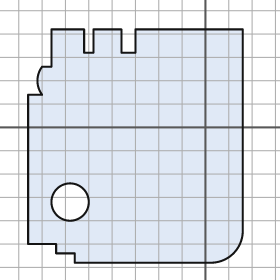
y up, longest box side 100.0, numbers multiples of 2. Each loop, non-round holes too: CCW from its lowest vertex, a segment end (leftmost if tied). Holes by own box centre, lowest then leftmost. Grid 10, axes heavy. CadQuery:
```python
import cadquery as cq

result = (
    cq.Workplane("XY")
    .moveTo(-56.0, -58.0)
    .lineTo(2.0, -58.0)
    .threePointArc((12.0, -54.0), (16.0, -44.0))
    .lineTo(16.0, 42.0)
    .lineTo(-30.0, 42.0)
    .lineTo(-30.0, 32.0)
    .lineTo(-36.0, 32.0)
    .lineTo(-36.0, 42.0)
    .lineTo(-48.0, 42.0)
    .lineTo(-48.0, 32.0)
    .lineTo(-52.0, 32.0)
    .lineTo(-52.0, 42.0)
    .lineTo(-66.0, 42.0)
    .lineTo(-66.0, 26.0)
    .lineTo(-70.0, 26.0)
    .threePointArc((-72.0, 20.0), (-70.0, 14.0))
    .lineTo(-76.0, 14.0)
    .lineTo(-76.0, -50.0)
    .lineTo(-64.0, -50.0)
    .lineTo(-64.0, -54.0)
    .lineTo(-56.0, -54.0)
    .close()
    .moveTo(-58.0, -32.0)
    .circle(8.0)
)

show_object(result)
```